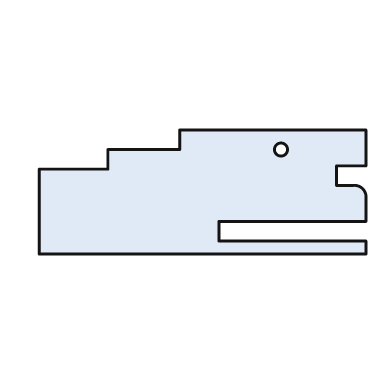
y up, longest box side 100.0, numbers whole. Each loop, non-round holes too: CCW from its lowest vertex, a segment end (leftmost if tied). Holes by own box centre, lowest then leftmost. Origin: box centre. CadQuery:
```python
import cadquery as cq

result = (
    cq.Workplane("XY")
    .moveTo(-50.0, -19.0)
    .lineTo(50.0, -19.0)
    .lineTo(50.0, -15.0)
    .lineTo(5.0, -15.0)
    .lineTo(5.0, -9.0)
    .lineTo(50.0, -9.0)
    .lineTo(50.0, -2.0)
    .threePointArc((49.0, 1.0), (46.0, 2.0))
    .lineTo(41.0, 2.0)
    .lineTo(41.0, 8.0)
    .lineTo(50.0, 8.0)
    .lineTo(50.0, 19.0)
    .lineTo(-7.0, 19.0)
    .lineTo(-7.0, 13.0)
    .lineTo(-29.0, 13.0)
    .lineTo(-29.0, 7.0)
    .lineTo(-50.0, 7.0)
    .close()
    .moveTo(24.0, 13.0)
    .circle(2.0)
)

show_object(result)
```